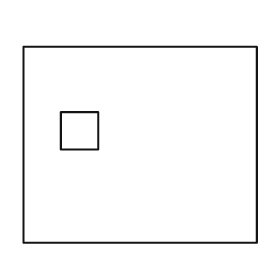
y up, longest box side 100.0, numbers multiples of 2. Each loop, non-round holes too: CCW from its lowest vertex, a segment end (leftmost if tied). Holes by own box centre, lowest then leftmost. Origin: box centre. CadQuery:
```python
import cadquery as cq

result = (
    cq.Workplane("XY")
    .moveTo(-50.0, -42.0)
    .lineTo(50.0, -42.0)
    .lineTo(50.0, 42.0)
    .lineTo(-50.0, 42.0)
    .close()
    .moveTo(-34.0, -2.0)
    .lineTo(-18.0, -2.0)
    .lineTo(-18.0, 14.0)
    .lineTo(-34.0, 14.0)
    .close()
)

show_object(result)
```